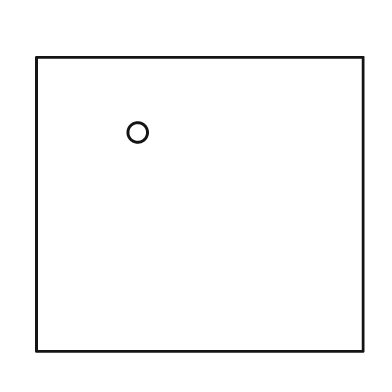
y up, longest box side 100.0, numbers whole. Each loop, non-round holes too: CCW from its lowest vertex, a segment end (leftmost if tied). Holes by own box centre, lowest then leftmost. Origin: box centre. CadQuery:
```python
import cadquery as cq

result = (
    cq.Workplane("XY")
    .moveTo(-50.0, -45.0)
    .lineTo(50.0, -45.0)
    .lineTo(50.0, 45.0)
    .lineTo(-50.0, 45.0)
    .close()
    .moveTo(-19.0, 22.0)
    .circle(3.0)
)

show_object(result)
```